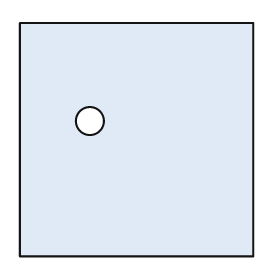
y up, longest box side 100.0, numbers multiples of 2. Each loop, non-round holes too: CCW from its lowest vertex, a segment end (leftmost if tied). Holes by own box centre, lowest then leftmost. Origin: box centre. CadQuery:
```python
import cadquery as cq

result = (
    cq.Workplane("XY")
    .moveTo(-50.0, -50.0)
    .lineTo(50.0, -50.0)
    .lineTo(50.0, 50.0)
    .lineTo(-50.0, 50.0)
    .close()
    .moveTo(-20.0, 8.0)
    .circle(6.0)
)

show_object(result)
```